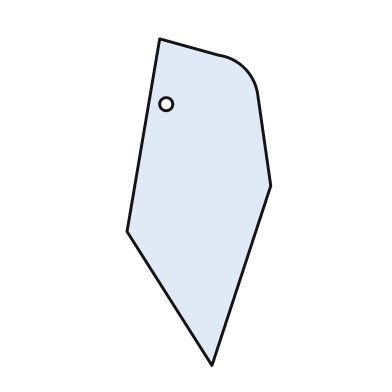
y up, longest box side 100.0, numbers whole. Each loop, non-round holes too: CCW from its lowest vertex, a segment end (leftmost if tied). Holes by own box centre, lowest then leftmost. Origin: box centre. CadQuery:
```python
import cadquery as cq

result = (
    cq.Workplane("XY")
    .moveTo(4.0, -50.0)
    .lineTo(22.0, 5.0)
    .lineTo(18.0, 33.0)
    .threePointArc((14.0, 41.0), (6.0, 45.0))
    .lineTo(-12.0, 50.0)
    .lineTo(-22.0, -9.0)
    .close()
    .moveTo(-10.0, 30.0)
    .circle(2.0)
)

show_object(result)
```